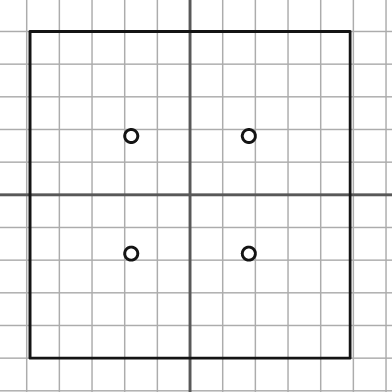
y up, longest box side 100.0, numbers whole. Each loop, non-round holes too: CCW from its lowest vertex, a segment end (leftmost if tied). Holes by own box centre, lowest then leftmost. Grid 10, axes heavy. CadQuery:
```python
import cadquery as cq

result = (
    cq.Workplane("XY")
    .moveTo(-49.0, -50.0)
    .lineTo(49.0, -50.0)
    .lineTo(49.0, 50.0)
    .lineTo(-49.0, 50.0)
    .close()
    .moveTo(-18.0, -18.0)
    .circle(2.0)
    .moveTo(18.0, -18.0)
    .circle(2.0)
    .moveTo(-18.0, 18.0)
    .circle(2.0)
    .moveTo(18.0, 18.0)
    .circle(2.0)
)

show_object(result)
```